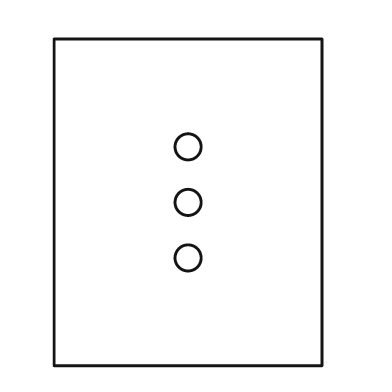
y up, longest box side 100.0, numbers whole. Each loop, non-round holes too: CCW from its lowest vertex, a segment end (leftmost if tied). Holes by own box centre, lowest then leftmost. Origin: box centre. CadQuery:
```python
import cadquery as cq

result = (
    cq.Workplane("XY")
    .moveTo(-41.0, -50.0)
    .lineTo(41.0, -50.0)
    .lineTo(41.0, 50.0)
    .lineTo(-41.0, 50.0)
    .close()
    .moveTo(0.0, -17.0)
    .circle(4.0)
    .moveTo(0.0, 0.0)
    .circle(4.0)
    .moveTo(0.0, 17.0)
    .circle(4.0)
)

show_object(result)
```